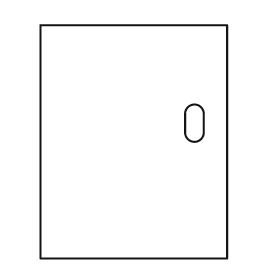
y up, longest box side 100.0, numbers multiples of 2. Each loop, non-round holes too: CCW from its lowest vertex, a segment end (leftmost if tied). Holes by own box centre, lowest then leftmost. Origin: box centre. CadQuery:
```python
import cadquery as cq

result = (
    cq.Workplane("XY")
    .moveTo(-40.0, -50.0)
    .lineTo(40.0, -50.0)
    .lineTo(40.0, 50.0)
    .lineTo(-40.0, 50.0)
    .close()
    .moveTo(22.0, 4.0)
    .threePointArc((26.0, 0.0), (30.0, 4.0))
    .lineTo(30.0, 12.0)
    .threePointArc((26.0, 16.0), (22.0, 12.0))
    .close()
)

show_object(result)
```